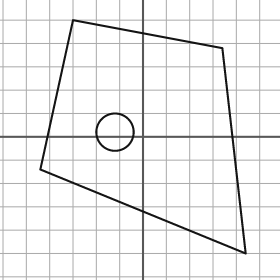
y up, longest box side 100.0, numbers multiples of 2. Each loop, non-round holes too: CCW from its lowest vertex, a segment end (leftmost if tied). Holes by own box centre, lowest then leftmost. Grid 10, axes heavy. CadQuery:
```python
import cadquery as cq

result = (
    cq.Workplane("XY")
    .moveTo(44.0, -50.0)
    .lineTo(34.0, 38.0)
    .lineTo(-30.0, 50.0)
    .lineTo(-44.0, -14.0)
    .close()
    .moveTo(-12.0, 2.0)
    .circle(8.0)
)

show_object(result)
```